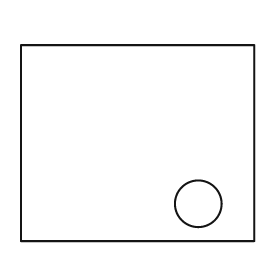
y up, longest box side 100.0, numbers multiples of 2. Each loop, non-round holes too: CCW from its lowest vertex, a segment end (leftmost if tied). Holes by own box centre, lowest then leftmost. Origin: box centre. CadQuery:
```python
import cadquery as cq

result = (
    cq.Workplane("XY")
    .moveTo(-50.0, -42.0)
    .lineTo(50.0, -42.0)
    .lineTo(50.0, 42.0)
    .lineTo(-50.0, 42.0)
    .close()
    .moveTo(26.0, -26.0)
    .circle(10.0)
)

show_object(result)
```